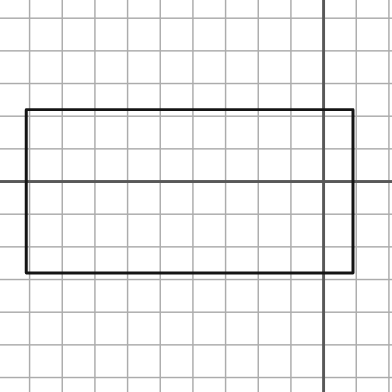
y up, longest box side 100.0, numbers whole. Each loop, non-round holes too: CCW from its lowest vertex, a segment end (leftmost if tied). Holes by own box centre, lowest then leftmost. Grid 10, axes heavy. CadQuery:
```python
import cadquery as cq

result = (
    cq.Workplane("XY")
    .moveTo(-91.0, -28.0)
    .lineTo(9.0, -28.0)
    .lineTo(9.0, 22.0)
    .lineTo(-91.0, 22.0)
    .close()
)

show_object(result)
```